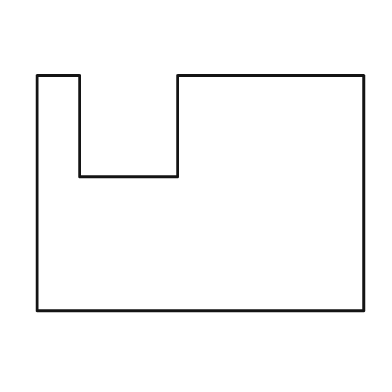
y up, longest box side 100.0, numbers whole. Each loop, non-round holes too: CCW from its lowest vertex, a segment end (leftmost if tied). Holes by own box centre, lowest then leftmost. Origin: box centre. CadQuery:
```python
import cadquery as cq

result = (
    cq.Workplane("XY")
    .moveTo(-50.0, -36.0)
    .lineTo(50.0, -36.0)
    .lineTo(50.0, 36.0)
    .lineTo(-7.0, 36.0)
    .lineTo(-7.0, 5.0)
    .lineTo(-37.0, 5.0)
    .lineTo(-37.0, 36.0)
    .lineTo(-50.0, 36.0)
    .close()
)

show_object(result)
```